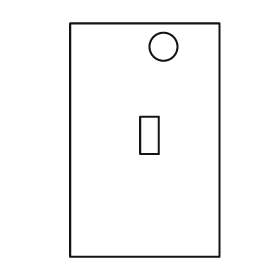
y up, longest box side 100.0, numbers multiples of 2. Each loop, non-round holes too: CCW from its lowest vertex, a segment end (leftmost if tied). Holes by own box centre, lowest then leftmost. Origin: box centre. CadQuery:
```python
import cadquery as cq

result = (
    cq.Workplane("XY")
    .moveTo(-32.0, -50.0)
    .lineTo(32.0, -50.0)
    .lineTo(32.0, 50.0)
    .lineTo(-32.0, 50.0)
    .close()
    .moveTo(-2.0, -6.0)
    .lineTo(6.0, -6.0)
    .lineTo(6.0, 10.0)
    .lineTo(-2.0, 10.0)
    .close()
    .moveTo(8.0, 40.0)
    .circle(6.0)
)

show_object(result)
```